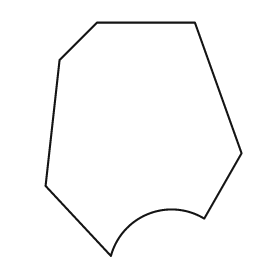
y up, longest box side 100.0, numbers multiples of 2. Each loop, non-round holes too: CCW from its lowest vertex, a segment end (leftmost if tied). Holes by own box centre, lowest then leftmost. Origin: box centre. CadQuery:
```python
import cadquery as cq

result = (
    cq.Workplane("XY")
    .moveTo(-14.0, -50.0)
    .threePointArc((2.0, -32.0), (26.0, -34.0))
    .lineTo(42.0, -6.0)
    .lineTo(22.0, 50.0)
    .lineTo(-20.0, 50.0)
    .lineTo(-36.0, 34.0)
    .lineTo(-42.0, -20.0)
    .close()
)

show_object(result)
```